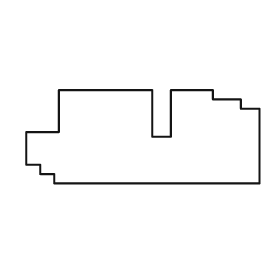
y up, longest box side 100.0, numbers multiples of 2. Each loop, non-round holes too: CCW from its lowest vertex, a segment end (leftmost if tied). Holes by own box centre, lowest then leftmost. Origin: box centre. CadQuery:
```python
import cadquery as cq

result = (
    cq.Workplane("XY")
    .moveTo(-38.0, -20.0)
    .lineTo(50.0, -20.0)
    .lineTo(50.0, 12.0)
    .lineTo(42.0, 12.0)
    .lineTo(42.0, 16.0)
    .lineTo(30.0, 16.0)
    .lineTo(30.0, 20.0)
    .lineTo(12.0, 20.0)
    .lineTo(12.0, 0.0)
    .lineTo(4.0, 0.0)
    .lineTo(4.0, 20.0)
    .lineTo(-36.0, 20.0)
    .lineTo(-36.0, 2.0)
    .lineTo(-50.0, 2.0)
    .lineTo(-50.0, -12.0)
    .lineTo(-44.0, -12.0)
    .lineTo(-44.0, -16.0)
    .lineTo(-38.0, -16.0)
    .close()
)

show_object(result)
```